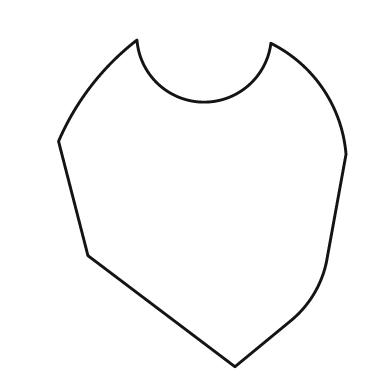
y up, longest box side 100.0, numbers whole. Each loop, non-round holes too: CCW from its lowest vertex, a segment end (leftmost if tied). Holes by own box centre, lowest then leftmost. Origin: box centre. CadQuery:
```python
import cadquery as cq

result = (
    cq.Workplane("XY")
    .moveTo(10.0, -50.0)
    .lineTo(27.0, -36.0)
    .threePointArc((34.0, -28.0), (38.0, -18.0))
    .lineTo(44.0, 15.0)
    .threePointArc((37.0, 35.0), (21.0, 49.0))
    .threePointArc((0.0, 31.0), (-20.0, 50.0))
    .threePointArc((-34.0, 36.0), (-44.0, 19.0))
    .lineTo(-35.0, -16.0)
    .close()
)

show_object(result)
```